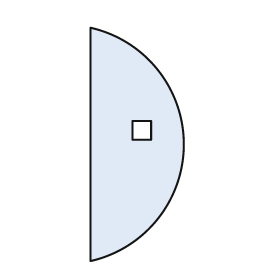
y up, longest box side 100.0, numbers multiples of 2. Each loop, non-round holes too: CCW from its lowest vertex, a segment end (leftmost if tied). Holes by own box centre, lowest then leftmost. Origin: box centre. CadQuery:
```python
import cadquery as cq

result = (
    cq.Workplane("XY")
    .moveTo(-20.0, -50.0)
    .threePointArc((20.0, 0.0), (-20.0, 50.0))
    .close()
    .moveTo(-2.0, 2.0)
    .lineTo(6.0, 2.0)
    .lineTo(6.0, 10.0)
    .lineTo(-2.0, 10.0)
    .close()
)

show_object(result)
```